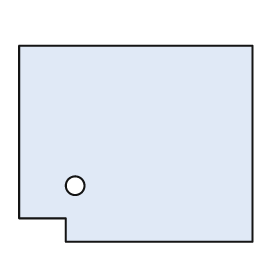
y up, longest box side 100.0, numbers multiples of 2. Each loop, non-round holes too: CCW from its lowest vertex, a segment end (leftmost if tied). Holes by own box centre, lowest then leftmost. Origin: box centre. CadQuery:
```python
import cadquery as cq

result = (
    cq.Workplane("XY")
    .moveTo(-30.0, -42.0)
    .lineTo(50.0, -42.0)
    .lineTo(50.0, 42.0)
    .lineTo(-50.0, 42.0)
    .lineTo(-50.0, -32.0)
    .lineTo(-30.0, -32.0)
    .close()
    .moveTo(-26.0, -18.0)
    .circle(4.0)
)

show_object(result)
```